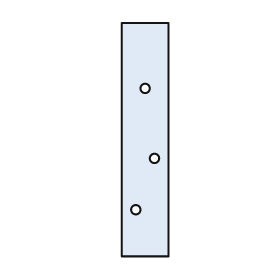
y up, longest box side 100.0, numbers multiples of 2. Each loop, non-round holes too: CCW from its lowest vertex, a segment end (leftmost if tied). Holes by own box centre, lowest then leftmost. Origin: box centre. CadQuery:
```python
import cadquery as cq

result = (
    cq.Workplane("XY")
    .moveTo(-10.0, -50.0)
    .lineTo(10.0, -50.0)
    .lineTo(10.0, 50.0)
    .lineTo(-10.0, 50.0)
    .close()
    .moveTo(-4.0, -30.0)
    .circle(2.0)
    .moveTo(4.0, -8.0)
    .circle(2.0)
    .moveTo(0.0, 22.0)
    .circle(2.0)
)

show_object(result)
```